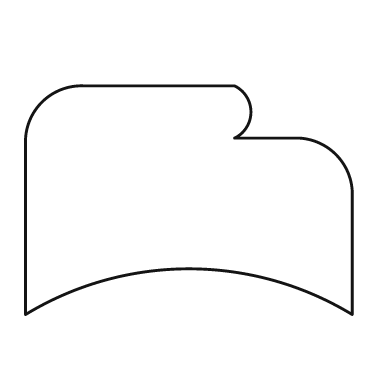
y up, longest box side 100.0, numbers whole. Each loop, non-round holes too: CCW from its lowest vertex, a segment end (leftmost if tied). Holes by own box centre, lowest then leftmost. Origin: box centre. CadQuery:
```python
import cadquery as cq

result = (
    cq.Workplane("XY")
    .moveTo(-50.0, -35.0)
    .threePointArc((0.0, -21.0), (50.0, -35.0))
    .lineTo(50.0, 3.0)
    .threePointArc((45.0, 14.0), (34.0, 19.0))
    .lineTo(14.0, 19.0)
    .threePointArc((19.0, 27.0), (14.0, 35.0))
    .lineTo(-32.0, 35.0)
    .threePointArc((-45.0, 30.0), (-50.0, 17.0))
    .close()
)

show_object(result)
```